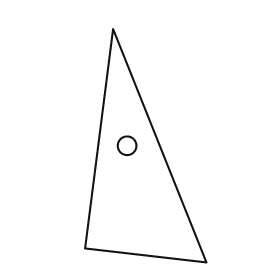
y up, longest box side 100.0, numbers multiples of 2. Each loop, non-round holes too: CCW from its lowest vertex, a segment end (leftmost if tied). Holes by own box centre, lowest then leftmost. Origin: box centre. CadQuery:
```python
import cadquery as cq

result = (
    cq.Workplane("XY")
    .moveTo(26.0, -50.0)
    .lineTo(-14.0, 50.0)
    .lineTo(-26.0, -44.0)
    .close()
    .moveTo(-8.0, 0.0)
    .circle(4.0)
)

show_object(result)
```